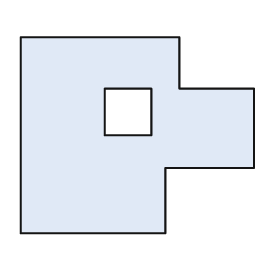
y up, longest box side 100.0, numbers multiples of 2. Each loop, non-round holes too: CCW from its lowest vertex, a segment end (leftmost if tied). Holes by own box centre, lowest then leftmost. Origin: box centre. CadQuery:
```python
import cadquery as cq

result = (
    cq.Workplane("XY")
    .moveTo(-50.0, -42.0)
    .lineTo(12.0, -42.0)
    .lineTo(12.0, -14.0)
    .lineTo(50.0, -14.0)
    .lineTo(50.0, 20.0)
    .lineTo(18.0, 20.0)
    .lineTo(18.0, 42.0)
    .lineTo(-50.0, 42.0)
    .close()
    .moveTo(-14.0, 0.0)
    .lineTo(6.0, 0.0)
    .lineTo(6.0, 20.0)
    .lineTo(-14.0, 20.0)
    .close()
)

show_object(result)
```